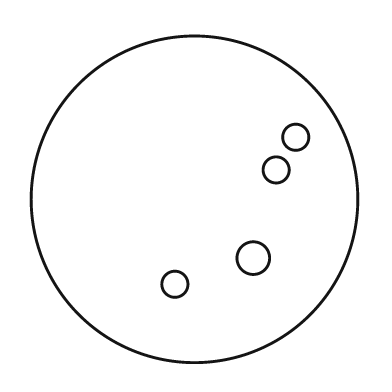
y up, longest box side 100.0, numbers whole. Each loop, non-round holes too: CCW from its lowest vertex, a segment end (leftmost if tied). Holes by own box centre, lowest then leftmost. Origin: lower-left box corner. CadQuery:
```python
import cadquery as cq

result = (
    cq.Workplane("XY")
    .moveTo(50.0, 50.0)
    .circle(50.0)
    .moveTo(44.0, 24.0)
    .circle(4.0)
    .moveTo(68.0, 32.0)
    .circle(5.0)
    .moveTo(75.0, 59.0)
    .circle(4.0)
    .moveTo(81.0, 69.0)
    .circle(4.0)
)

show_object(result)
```